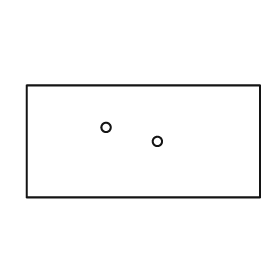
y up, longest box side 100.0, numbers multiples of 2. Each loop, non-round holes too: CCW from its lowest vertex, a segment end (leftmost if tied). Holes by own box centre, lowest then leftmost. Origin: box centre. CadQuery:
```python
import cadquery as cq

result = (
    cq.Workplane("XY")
    .moveTo(-50.0, -24.0)
    .lineTo(50.0, -24.0)
    .lineTo(50.0, 24.0)
    .lineTo(-50.0, 24.0)
    .close()
    .moveTo(6.0, 0.0)
    .circle(2.0)
    .moveTo(-16.0, 6.0)
    .circle(2.0)
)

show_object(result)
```